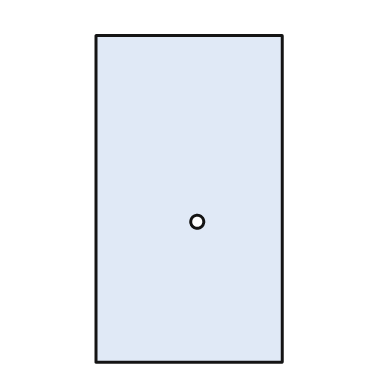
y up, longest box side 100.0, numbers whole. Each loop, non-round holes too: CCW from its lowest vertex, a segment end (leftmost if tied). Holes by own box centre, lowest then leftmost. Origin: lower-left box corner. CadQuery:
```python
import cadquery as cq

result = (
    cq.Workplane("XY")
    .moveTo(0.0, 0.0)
    .lineTo(57.0, 0.0)
    .lineTo(57.0, 100.0)
    .lineTo(0.0, 100.0)
    .close()
    .moveTo(31.0, 43.0)
    .circle(2.0)
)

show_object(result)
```